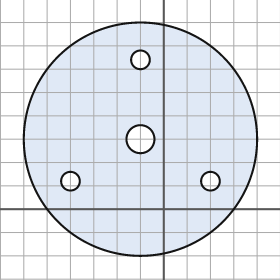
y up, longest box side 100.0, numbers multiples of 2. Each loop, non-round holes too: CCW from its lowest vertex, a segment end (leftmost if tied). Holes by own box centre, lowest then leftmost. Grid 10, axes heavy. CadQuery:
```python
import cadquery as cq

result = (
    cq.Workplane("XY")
    .moveTo(-10.0, 30.0)
    .circle(50.0)
    .moveTo(-40.0, 12.0)
    .circle(4.0)
    .moveTo(20.0, 12.0)
    .circle(4.0)
    .moveTo(-10.0, 30.0)
    .circle(6.0)
    .moveTo(-10.0, 64.0)
    .circle(4.0)
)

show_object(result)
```